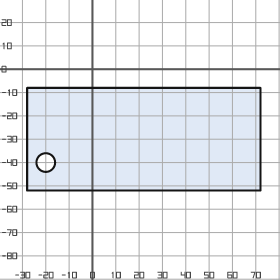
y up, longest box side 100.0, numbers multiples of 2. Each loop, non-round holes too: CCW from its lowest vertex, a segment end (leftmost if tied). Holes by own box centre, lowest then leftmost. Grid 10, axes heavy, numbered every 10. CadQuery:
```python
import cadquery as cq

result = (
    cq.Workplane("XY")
    .moveTo(-28.0, -52.0)
    .lineTo(72.0, -52.0)
    .lineTo(72.0, -8.0)
    .lineTo(-28.0, -8.0)
    .close()
    .moveTo(-20.0, -40.0)
    .circle(4.0)
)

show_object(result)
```